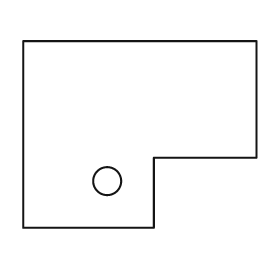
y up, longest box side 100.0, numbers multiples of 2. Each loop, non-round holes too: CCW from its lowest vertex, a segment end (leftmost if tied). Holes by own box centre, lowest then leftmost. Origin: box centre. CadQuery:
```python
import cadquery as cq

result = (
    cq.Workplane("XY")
    .moveTo(-50.0, -40.0)
    .lineTo(6.0, -40.0)
    .lineTo(6.0, -10.0)
    .lineTo(50.0, -10.0)
    .lineTo(50.0, 40.0)
    .lineTo(-50.0, 40.0)
    .close()
    .moveTo(-14.0, -20.0)
    .circle(6.0)
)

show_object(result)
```